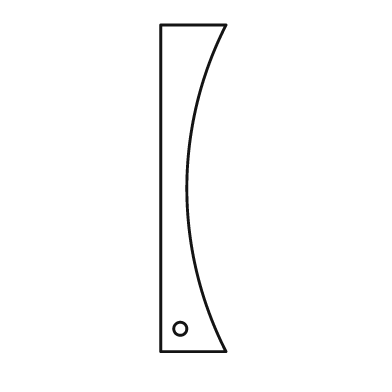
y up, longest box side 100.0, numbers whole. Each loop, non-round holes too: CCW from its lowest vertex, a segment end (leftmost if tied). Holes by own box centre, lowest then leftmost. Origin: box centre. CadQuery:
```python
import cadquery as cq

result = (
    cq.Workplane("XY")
    .moveTo(-10.0, -50.0)
    .lineTo(10.0, -50.0)
    .threePointArc((-2.0, 0.0), (10.0, 50.0))
    .lineTo(-10.0, 50.0)
    .close()
    .moveTo(-4.0, -43.0)
    .circle(2.0)
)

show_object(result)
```